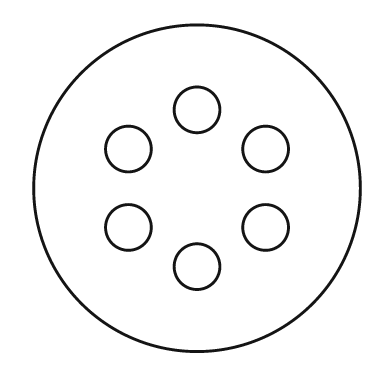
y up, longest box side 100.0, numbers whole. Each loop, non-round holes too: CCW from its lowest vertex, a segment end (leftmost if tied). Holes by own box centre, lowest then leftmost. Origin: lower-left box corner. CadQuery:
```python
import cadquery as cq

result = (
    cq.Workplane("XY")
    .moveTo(50.0, 50.0)
    .circle(50.0)
    .moveTo(50.0, 26.0)
    .circle(7.0)
    .moveTo(29.0, 38.0)
    .circle(7.0)
    .moveTo(71.0, 38.0)
    .circle(7.0)
    .moveTo(29.0, 62.0)
    .circle(7.0)
    .moveTo(71.0, 62.0)
    .circle(7.0)
    .moveTo(50.0, 74.0)
    .circle(7.0)
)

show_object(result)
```